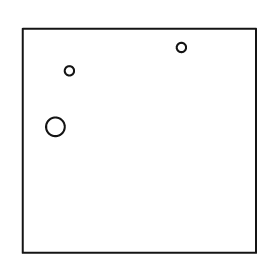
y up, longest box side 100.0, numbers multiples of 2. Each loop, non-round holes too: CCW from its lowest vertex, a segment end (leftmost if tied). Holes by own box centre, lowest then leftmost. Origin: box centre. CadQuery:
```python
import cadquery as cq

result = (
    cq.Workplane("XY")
    .moveTo(-50.0, -48.0)
    .lineTo(50.0, -48.0)
    .lineTo(50.0, 48.0)
    .lineTo(-50.0, 48.0)
    .close()
    .moveTo(-36.0, 6.0)
    .circle(4.0)
    .moveTo(-30.0, 30.0)
    .circle(2.0)
    .moveTo(18.0, 40.0)
    .circle(2.0)
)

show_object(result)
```